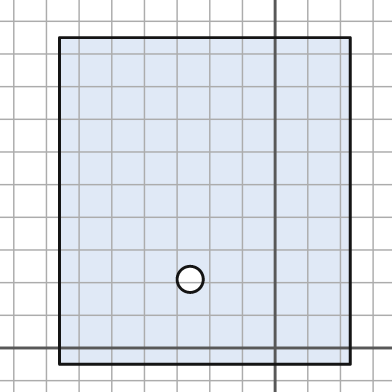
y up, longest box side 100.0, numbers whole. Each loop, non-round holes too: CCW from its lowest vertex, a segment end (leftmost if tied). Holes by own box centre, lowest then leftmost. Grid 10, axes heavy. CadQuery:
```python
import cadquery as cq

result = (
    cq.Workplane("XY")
    .moveTo(-66.0, -5.0)
    .lineTo(23.0, -5.0)
    .lineTo(23.0, 95.0)
    .lineTo(-66.0, 95.0)
    .close()
    .moveTo(-26.0, 21.0)
    .circle(4.0)
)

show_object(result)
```